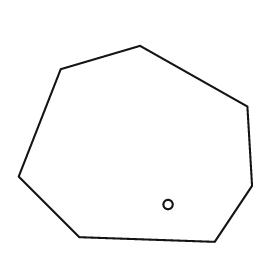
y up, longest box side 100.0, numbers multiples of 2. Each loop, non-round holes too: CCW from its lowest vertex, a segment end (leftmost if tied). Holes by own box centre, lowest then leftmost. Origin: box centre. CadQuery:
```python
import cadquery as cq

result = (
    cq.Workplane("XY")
    .moveTo(34.0, -42.0)
    .lineTo(50.0, -18.0)
    .lineTo(48.0, 16.0)
    .lineTo(2.0, 42.0)
    .lineTo(-32.0, 32.0)
    .lineTo(-50.0, -14.0)
    .lineTo(-24.0, -40.0)
    .close()
    .moveTo(14.0, -26.0)
    .circle(2.0)
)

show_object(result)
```